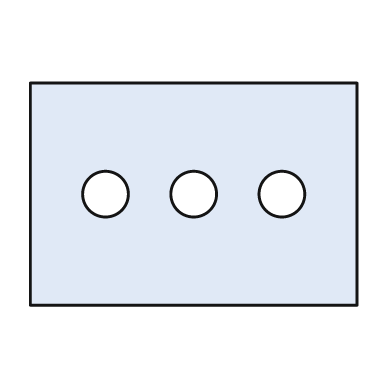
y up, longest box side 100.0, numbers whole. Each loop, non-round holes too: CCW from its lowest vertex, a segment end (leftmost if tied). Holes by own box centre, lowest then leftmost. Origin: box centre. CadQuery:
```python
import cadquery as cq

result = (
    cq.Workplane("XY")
    .moveTo(-50.0, -34.0)
    .lineTo(50.0, -34.0)
    .lineTo(50.0, 34.0)
    .lineTo(-50.0, 34.0)
    .close()
    .moveTo(-27.0, 0.0)
    .circle(7.0)
    .moveTo(0.0, 0.0)
    .circle(7.0)
    .moveTo(27.0, 0.0)
    .circle(7.0)
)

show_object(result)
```